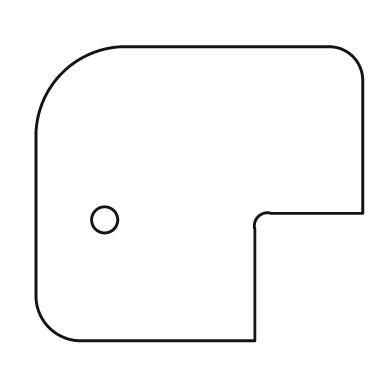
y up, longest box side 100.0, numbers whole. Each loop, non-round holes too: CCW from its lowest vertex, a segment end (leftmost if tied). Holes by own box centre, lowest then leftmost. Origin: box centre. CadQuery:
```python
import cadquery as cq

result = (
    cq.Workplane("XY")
    .moveTo(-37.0, -45.0)
    .lineTo(17.0, -45.0)
    .lineTo(17.0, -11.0)
    .threePointArc((18.0, -7.0), (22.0, -6.0))
    .lineTo(50.0, -6.0)
    .lineTo(50.0, 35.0)
    .threePointArc((47.0, 42.0), (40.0, 45.0))
    .lineTo(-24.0, 45.0)
    .threePointArc((-42.0, 37.0), (-50.0, 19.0))
    .lineTo(-50.0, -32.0)
    .threePointArc((-46.0, -41.0), (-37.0, -45.0))
    .close()
    .moveTo(-29.0, -8.0)
    .circle(4.0)
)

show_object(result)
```